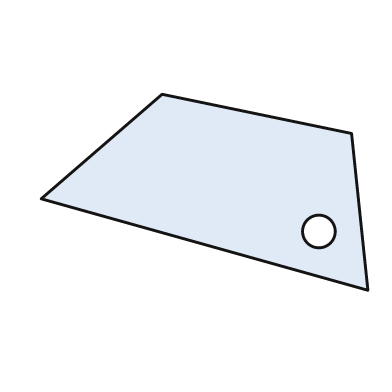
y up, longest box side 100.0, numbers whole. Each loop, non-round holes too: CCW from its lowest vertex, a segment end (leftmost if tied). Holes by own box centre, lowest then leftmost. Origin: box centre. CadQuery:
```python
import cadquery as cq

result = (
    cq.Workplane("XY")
    .moveTo(50.0, -30.0)
    .lineTo(45.0, 18.0)
    .lineTo(-13.0, 30.0)
    .lineTo(-50.0, -2.0)
    .close()
    .moveTo(35.0, -12.0)
    .circle(5.0)
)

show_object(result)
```